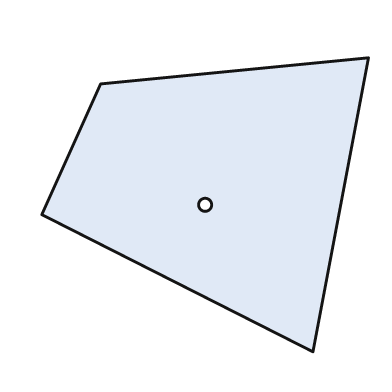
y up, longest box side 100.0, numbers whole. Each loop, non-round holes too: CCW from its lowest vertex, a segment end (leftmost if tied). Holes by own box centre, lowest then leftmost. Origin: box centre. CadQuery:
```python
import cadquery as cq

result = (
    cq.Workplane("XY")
    .moveTo(33.0, -45.0)
    .lineTo(50.0, 45.0)
    .lineTo(-32.0, 37.0)
    .lineTo(-50.0, -3.0)
    .close()
    .moveTo(0.0, 0.0)
    .circle(2.0)
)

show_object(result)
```